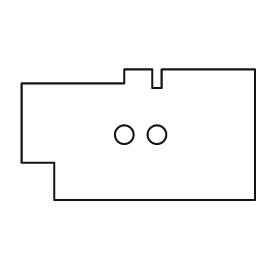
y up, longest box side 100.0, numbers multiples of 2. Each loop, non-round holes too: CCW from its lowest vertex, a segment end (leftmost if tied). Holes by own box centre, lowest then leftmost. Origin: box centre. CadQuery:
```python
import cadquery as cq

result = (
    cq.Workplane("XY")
    .moveTo(-36.0, -28.0)
    .lineTo(50.0, -28.0)
    .lineTo(50.0, 28.0)
    .lineTo(10.0, 28.0)
    .lineTo(10.0, 20.0)
    .lineTo(6.0, 20.0)
    .lineTo(6.0, 28.0)
    .lineTo(-6.0, 28.0)
    .lineTo(-6.0, 22.0)
    .lineTo(-50.0, 22.0)
    .lineTo(-50.0, -12.0)
    .lineTo(-36.0, -12.0)
    .close()
    .moveTo(-6.0, 0.0)
    .circle(4.0)
    .moveTo(8.0, 0.0)
    .circle(4.0)
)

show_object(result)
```